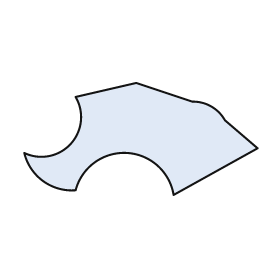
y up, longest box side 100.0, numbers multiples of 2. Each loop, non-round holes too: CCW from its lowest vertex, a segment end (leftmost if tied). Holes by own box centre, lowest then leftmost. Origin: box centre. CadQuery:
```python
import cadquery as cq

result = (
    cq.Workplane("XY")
    .moveTo(14.0, -24.0)
    .lineTo(50.0, -4.0)
    .lineTo(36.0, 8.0)
    .threePointArc((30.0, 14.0), (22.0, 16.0))
    .lineTo(-2.0, 24.0)
    .lineTo(-28.0, 18.0)
    .threePointArc((-30.0, -2.0), (-50.0, -6.0))
    .threePointArc((-42.0, -18.0), (-28.0, -22.0))
    .threePointArc((-6.0, -6.0), (14.0, -24.0))
    .close()
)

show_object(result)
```